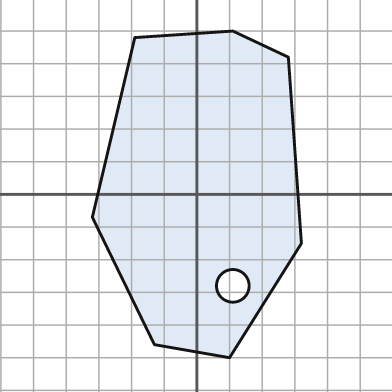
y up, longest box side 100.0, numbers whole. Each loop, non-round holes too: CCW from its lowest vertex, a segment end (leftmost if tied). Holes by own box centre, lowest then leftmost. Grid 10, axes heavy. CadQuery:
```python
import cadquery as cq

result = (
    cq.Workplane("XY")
    .moveTo(10.0, -50.0)
    .lineTo(32.0, -15.0)
    .lineTo(28.0, 42.0)
    .lineTo(11.0, 50.0)
    .lineTo(-19.0, 48.0)
    .lineTo(-32.0, -7.0)
    .lineTo(-13.0, -46.0)
    .close()
    .moveTo(11.0, -28.0)
    .circle(5.0)
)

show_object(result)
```